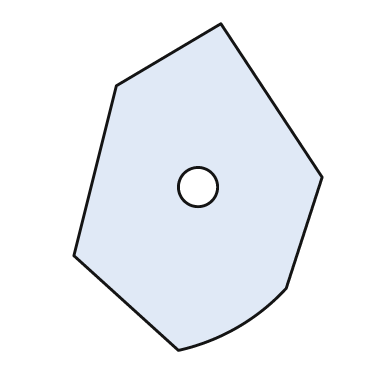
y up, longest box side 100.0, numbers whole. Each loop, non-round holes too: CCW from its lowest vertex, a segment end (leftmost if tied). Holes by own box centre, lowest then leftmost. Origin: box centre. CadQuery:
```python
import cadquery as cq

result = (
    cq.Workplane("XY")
    .moveTo(-6.0, -50.0)
    .threePointArc((12.0, -43.0), (27.0, -31.0))
    .lineTo(38.0, 3.0)
    .lineTo(7.0, 50.0)
    .lineTo(-25.0, 31.0)
    .lineTo(-38.0, -21.0)
    .close()
    .moveTo(0.0, 0.0)
    .circle(6.0)
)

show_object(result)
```